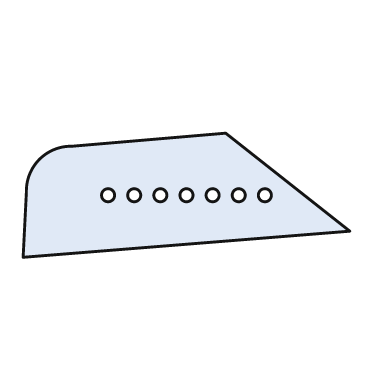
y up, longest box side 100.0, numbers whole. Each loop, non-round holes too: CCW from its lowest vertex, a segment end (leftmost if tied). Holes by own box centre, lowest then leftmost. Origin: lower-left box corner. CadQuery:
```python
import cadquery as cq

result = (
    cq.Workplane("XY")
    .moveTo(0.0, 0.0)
    .lineTo(100.0, 8.0)
    .lineTo(62.0, 38.0)
    .lineTo(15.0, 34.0)
    .threePointArc((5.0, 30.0), (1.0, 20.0))
    .close()
    .moveTo(26.0, 19.0)
    .circle(2.0)
    .moveTo(34.0, 19.0)
    .circle(2.0)
    .moveTo(42.0, 19.0)
    .circle(2.0)
    .moveTo(50.0, 19.0)
    .circle(2.0)
    .moveTo(58.0, 19.0)
    .circle(2.0)
    .moveTo(66.0, 19.0)
    .circle(2.0)
    .moveTo(74.0, 19.0)
    .circle(2.0)
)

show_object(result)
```